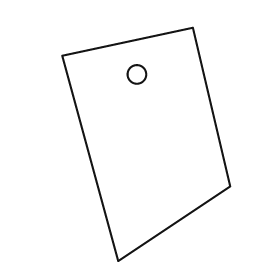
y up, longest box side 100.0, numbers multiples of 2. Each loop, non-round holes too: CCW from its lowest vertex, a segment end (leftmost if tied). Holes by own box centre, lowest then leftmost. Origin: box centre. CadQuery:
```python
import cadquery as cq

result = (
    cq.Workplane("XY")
    .moveTo(-12.0, -50.0)
    .lineTo(36.0, -18.0)
    .lineTo(20.0, 50.0)
    .lineTo(-36.0, 38.0)
    .close()
    .moveTo(-4.0, 30.0)
    .circle(4.0)
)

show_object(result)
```